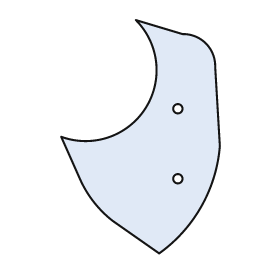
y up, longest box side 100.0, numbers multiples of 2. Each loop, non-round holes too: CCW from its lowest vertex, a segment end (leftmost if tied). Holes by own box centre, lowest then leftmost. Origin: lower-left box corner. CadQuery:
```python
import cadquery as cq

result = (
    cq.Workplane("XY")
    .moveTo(42.0, 0.0)
    .threePointArc((60.0, 20.0), (68.0, 46.0))
    .lineTo(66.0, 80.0)
    .threePointArc((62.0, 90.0), (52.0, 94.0))
    .lineTo(32.0, 100.0)
    .threePointArc((36.0, 62.0), (0.0, 50.0))
    .lineTo(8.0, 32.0)
    .threePointArc((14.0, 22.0), (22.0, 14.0))
    .close()
    .moveTo(50.0, 32.0)
    .circle(2.0)
    .moveTo(50.0, 62.0)
    .circle(2.0)
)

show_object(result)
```